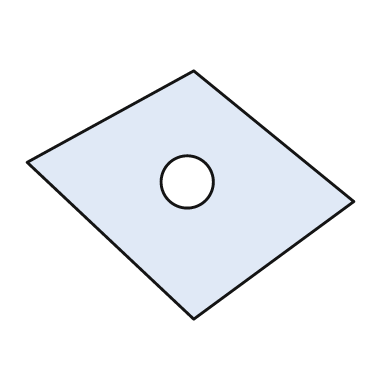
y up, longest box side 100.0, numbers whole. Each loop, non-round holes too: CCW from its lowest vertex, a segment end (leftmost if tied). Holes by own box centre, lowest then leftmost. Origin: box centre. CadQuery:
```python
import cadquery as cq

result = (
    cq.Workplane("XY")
    .moveTo(1.0, -38.0)
    .lineTo(50.0, -2.0)
    .lineTo(1.0, 38.0)
    .lineTo(-50.0, 10.0)
    .close()
    .moveTo(-1.0, 4.0)
    .circle(8.0)
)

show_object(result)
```